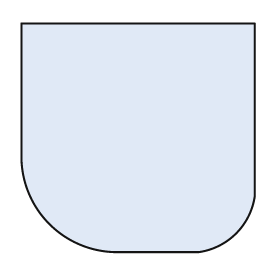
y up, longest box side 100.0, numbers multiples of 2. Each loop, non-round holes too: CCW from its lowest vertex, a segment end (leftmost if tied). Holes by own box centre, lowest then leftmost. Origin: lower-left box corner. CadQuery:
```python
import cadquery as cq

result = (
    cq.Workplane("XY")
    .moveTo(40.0, 0.0)
    .lineTo(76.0, 0.0)
    .threePointArc((92.0, 8.0), (100.0, 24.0))
    .lineTo(100.0, 98.0)
    .lineTo(0.0, 98.0)
    .lineTo(0.0, 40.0)
    .threePointArc((12.0, 12.0), (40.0, 0.0))
    .close()
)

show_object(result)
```